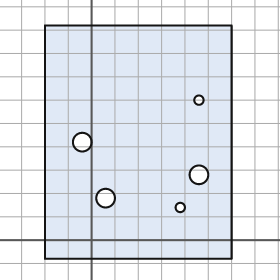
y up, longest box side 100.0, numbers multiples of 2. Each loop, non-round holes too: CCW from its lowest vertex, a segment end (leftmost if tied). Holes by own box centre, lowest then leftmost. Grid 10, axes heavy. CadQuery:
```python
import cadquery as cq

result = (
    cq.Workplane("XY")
    .moveTo(-20.0, -8.0)
    .lineTo(60.0, -8.0)
    .lineTo(60.0, 92.0)
    .lineTo(-20.0, 92.0)
    .close()
    .moveTo(38.0, 14.0)
    .circle(2.0)
    .moveTo(6.0, 18.0)
    .circle(4.0)
    .moveTo(46.0, 28.0)
    .circle(4.0)
    .moveTo(-4.0, 42.0)
    .circle(4.0)
    .moveTo(46.0, 60.0)
    .circle(2.0)
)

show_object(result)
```